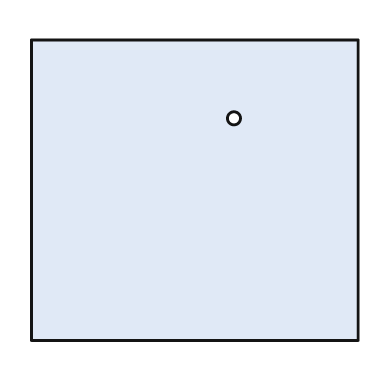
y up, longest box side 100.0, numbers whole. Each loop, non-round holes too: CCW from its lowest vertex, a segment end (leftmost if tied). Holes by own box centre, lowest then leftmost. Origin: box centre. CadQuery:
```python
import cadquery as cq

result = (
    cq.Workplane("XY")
    .moveTo(-50.0, -46.0)
    .lineTo(50.0, -46.0)
    .lineTo(50.0, 46.0)
    .lineTo(-50.0, 46.0)
    .close()
    .moveTo(12.0, 22.0)
    .circle(2.0)
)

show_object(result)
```